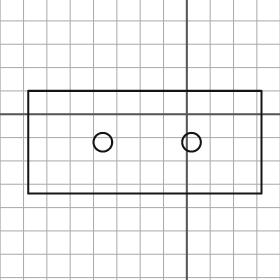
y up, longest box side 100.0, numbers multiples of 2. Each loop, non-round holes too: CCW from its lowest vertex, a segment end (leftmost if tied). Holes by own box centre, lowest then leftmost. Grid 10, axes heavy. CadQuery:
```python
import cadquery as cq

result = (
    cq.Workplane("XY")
    .moveTo(-68.0, -34.0)
    .lineTo(32.0, -34.0)
    .lineTo(32.0, 10.0)
    .lineTo(-68.0, 10.0)
    .close()
    .moveTo(-36.0, -12.0)
    .circle(4.0)
    .moveTo(2.0, -12.0)
    .circle(4.0)
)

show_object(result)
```